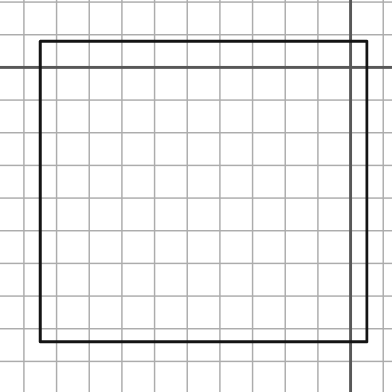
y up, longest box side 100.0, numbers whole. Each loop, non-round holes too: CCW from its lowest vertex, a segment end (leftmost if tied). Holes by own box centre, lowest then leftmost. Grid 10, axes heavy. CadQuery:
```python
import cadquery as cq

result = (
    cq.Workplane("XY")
    .moveTo(-95.0, -84.0)
    .lineTo(5.0, -84.0)
    .lineTo(5.0, 8.0)
    .lineTo(-95.0, 8.0)
    .close()
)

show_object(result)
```